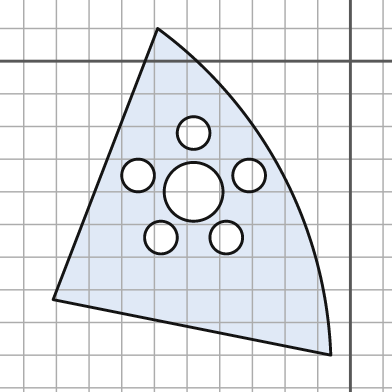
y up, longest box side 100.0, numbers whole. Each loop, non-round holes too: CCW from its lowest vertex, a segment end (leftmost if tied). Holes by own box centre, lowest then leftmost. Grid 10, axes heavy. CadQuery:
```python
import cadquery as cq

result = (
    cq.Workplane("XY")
    .moveTo(-6.0, -90.0)
    .threePointArc((-21.0, -34.0), (-59.0, 10.0))
    .lineTo(-91.0, -73.0)
    .close()
    .moveTo(-58.0, -54.0)
    .circle(5.0)
    .moveTo(-38.0, -54.0)
    .circle(5.0)
    .moveTo(-48.0, -40.0)
    .circle(9.0)
    .moveTo(-65.0, -35.0)
    .circle(5.0)
    .moveTo(-31.0, -35.0)
    .circle(5.0)
    .moveTo(-48.0, -22.0)
    .circle(5.0)
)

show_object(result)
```